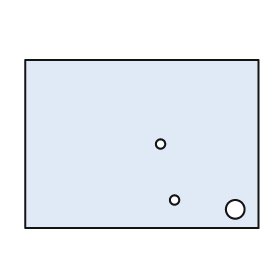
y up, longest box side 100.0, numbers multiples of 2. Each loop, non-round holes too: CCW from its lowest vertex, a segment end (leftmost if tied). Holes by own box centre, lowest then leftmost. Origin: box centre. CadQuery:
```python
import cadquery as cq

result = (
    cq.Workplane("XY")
    .moveTo(-50.0, -36.0)
    .lineTo(50.0, -36.0)
    .lineTo(50.0, 36.0)
    .lineTo(-50.0, 36.0)
    .close()
    .moveTo(40.0, -28.0)
    .circle(4.0)
    .moveTo(14.0, -24.0)
    .circle(2.0)
    .moveTo(8.0, 0.0)
    .circle(2.0)
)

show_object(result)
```